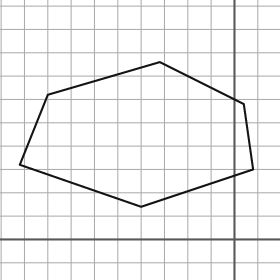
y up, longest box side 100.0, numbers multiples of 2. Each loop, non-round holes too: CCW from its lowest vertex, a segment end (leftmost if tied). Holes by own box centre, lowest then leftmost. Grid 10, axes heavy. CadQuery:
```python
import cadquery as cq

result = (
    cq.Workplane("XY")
    .moveTo(-40.0, 14.0)
    .lineTo(8.0, 30.0)
    .lineTo(4.0, 58.0)
    .lineTo(-32.0, 76.0)
    .lineTo(-80.0, 62.0)
    .lineTo(-92.0, 32.0)
    .close()
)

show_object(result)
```